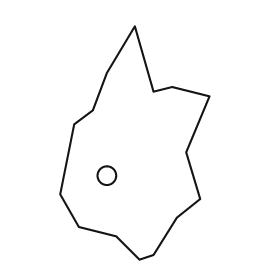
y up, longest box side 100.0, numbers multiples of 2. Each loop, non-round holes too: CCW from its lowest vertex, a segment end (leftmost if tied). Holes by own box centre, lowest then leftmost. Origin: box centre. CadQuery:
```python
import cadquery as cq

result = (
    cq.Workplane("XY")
    .moveTo(2.0, -50.0)
    .lineTo(8.0, -48.0)
    .lineTo(18.0, -32.0)
    .lineTo(28.0, -24.0)
    .lineTo(22.0, -4.0)
    .lineTo(32.0, 20.0)
    .lineTo(16.0, 24.0)
    .lineTo(8.0, 22.0)
    .lineTo(0.0, 50.0)
    .lineTo(-12.0, 30.0)
    .lineTo(-18.0, 14.0)
    .lineTo(-26.0, 8.0)
    .lineTo(-32.0, -22.0)
    .lineTo(-24.0, -36.0)
    .lineTo(-8.0, -40.0)
    .close()
    .moveTo(-12.0, -14.0)
    .circle(4.0)
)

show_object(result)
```